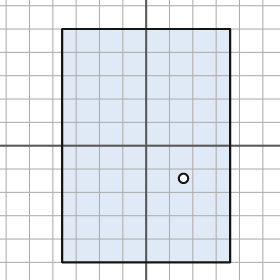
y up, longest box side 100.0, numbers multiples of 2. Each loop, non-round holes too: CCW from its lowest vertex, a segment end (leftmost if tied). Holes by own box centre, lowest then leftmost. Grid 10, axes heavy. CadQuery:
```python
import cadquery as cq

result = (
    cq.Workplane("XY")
    .moveTo(-36.0, -50.0)
    .lineTo(36.0, -50.0)
    .lineTo(36.0, 50.0)
    .lineTo(-36.0, 50.0)
    .close()
    .moveTo(16.0, -14.0)
    .circle(2.0)
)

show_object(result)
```